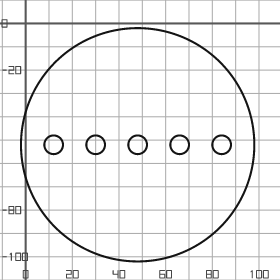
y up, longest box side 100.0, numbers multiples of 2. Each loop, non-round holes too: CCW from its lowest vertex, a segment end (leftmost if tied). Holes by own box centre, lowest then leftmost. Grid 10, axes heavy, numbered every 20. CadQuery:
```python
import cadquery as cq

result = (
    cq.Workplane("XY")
    .moveTo(48.0, -52.0)
    .circle(50.0)
    .moveTo(12.0, -52.0)
    .circle(4.0)
    .moveTo(30.0, -52.0)
    .circle(4.0)
    .moveTo(48.0, -52.0)
    .circle(4.0)
    .moveTo(66.0, -52.0)
    .circle(4.0)
    .moveTo(84.0, -52.0)
    .circle(4.0)
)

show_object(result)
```